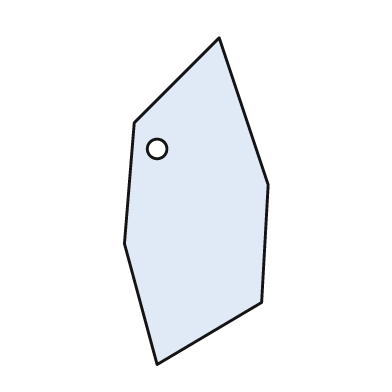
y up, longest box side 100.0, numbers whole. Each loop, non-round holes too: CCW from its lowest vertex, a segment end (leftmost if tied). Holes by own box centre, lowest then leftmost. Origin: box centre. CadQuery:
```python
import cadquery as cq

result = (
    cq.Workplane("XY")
    .moveTo(-12.0, -50.0)
    .lineTo(20.0, -31.0)
    .lineTo(22.0, 5.0)
    .lineTo(7.0, 50.0)
    .lineTo(-19.0, 24.0)
    .lineTo(-22.0, -13.0)
    .close()
    .moveTo(-12.0, 16.0)
    .circle(3.0)
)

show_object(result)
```